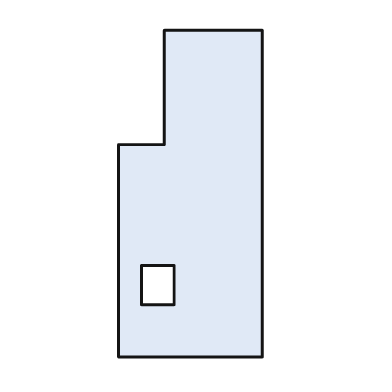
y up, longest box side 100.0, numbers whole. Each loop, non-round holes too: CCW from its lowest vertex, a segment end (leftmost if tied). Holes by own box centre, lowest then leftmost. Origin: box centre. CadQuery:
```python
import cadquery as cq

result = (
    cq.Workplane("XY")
    .moveTo(-22.0, -50.0)
    .lineTo(22.0, -50.0)
    .lineTo(22.0, 50.0)
    .lineTo(-8.0, 50.0)
    .lineTo(-8.0, 15.0)
    .lineTo(-22.0, 15.0)
    .close()
    .moveTo(-15.0, -34.0)
    .lineTo(-5.0, -34.0)
    .lineTo(-5.0, -22.0)
    .lineTo(-15.0, -22.0)
    .close()
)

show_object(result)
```